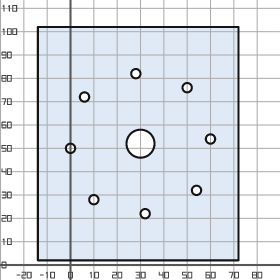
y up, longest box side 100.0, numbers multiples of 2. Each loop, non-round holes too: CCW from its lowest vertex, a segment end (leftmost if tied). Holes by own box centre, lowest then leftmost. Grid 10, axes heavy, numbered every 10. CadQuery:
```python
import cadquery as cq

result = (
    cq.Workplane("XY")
    .moveTo(-14.0, 2.0)
    .lineTo(72.0, 2.0)
    .lineTo(72.0, 102.0)
    .lineTo(-14.0, 102.0)
    .close()
    .moveTo(32.0, 22.0)
    .circle(2.0)
    .moveTo(10.0, 28.0)
    .circle(2.0)
    .moveTo(54.0, 32.0)
    .circle(2.0)
    .moveTo(0.0, 50.0)
    .circle(2.0)
    .moveTo(30.0, 52.0)
    .circle(6.0)
    .moveTo(60.0, 54.0)
    .circle(2.0)
    .moveTo(6.0, 72.0)
    .circle(2.0)
    .moveTo(50.0, 76.0)
    .circle(2.0)
    .moveTo(28.0, 82.0)
    .circle(2.0)
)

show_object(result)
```